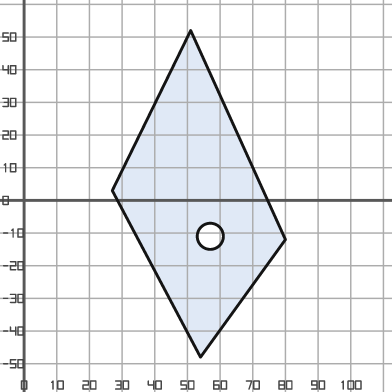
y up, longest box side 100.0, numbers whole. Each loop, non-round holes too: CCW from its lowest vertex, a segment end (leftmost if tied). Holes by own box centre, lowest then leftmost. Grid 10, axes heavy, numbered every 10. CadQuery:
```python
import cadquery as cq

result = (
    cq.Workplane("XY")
    .moveTo(54.0, -48.0)
    .lineTo(80.0, -12.0)
    .lineTo(51.0, 52.0)
    .lineTo(27.0, 3.0)
    .close()
    .moveTo(57.0, -11.0)
    .circle(4.0)
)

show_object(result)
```